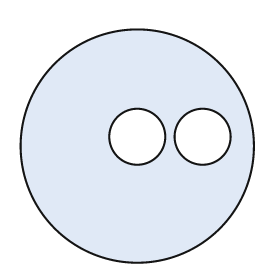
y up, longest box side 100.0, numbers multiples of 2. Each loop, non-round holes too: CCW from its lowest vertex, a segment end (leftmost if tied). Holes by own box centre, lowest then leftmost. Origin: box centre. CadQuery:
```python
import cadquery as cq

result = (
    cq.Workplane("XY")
    .moveTo(0.0, 0.0)
    .circle(50.0)
    .moveTo(0.0, 4.0)
    .circle(12.0)
    .moveTo(28.0, 4.0)
    .circle(12.0)
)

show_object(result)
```